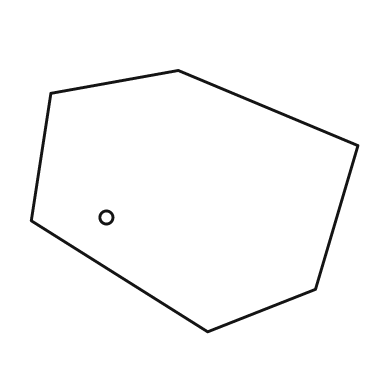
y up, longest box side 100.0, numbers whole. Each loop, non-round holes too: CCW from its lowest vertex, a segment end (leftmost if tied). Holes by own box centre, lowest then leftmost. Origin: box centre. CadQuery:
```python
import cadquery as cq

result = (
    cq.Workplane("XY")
    .moveTo(4.0, -40.0)
    .lineTo(37.0, -27.0)
    .lineTo(50.0, 17.0)
    .lineTo(-5.0, 40.0)
    .lineTo(-44.0, 33.0)
    .lineTo(-50.0, -6.0)
    .close()
    .moveTo(-27.0, -5.0)
    .circle(2.0)
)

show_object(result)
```